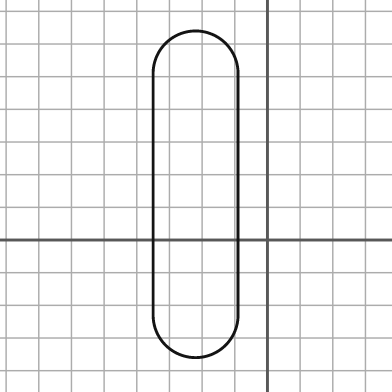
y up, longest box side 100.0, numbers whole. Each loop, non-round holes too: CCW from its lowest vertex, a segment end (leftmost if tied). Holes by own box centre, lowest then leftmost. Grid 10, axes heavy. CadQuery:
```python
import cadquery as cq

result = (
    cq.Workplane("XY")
    .moveTo(-35.0, -23.0)
    .threePointArc((-22.0, -36.0), (-9.0, -23.0))
    .lineTo(-9.0, 51.0)
    .threePointArc((-22.0, 64.0), (-35.0, 51.0))
    .close()
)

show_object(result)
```